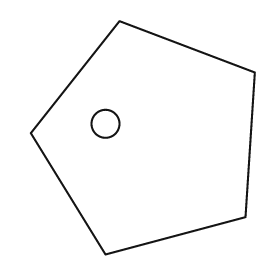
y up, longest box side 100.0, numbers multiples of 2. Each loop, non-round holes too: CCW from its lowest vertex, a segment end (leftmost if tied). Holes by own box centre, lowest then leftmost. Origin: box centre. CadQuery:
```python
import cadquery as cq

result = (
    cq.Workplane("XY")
    .moveTo(-16.0, -50.0)
    .lineTo(44.0, -34.0)
    .lineTo(48.0, 28.0)
    .lineTo(-10.0, 50.0)
    .lineTo(-48.0, 2.0)
    .close()
    .moveTo(-16.0, 6.0)
    .circle(6.0)
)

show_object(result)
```